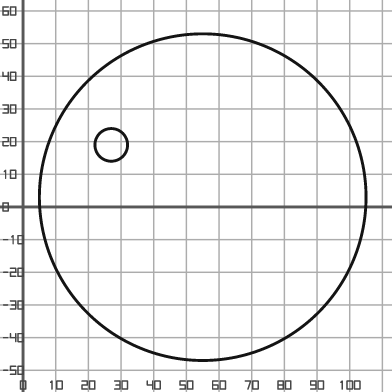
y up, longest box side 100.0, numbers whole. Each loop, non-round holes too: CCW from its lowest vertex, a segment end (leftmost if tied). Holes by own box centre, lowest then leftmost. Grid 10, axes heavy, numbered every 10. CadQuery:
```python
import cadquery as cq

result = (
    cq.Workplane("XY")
    .moveTo(55.0, 3.0)
    .circle(50.0)
    .moveTo(27.0, 19.0)
    .circle(5.0)
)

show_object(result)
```